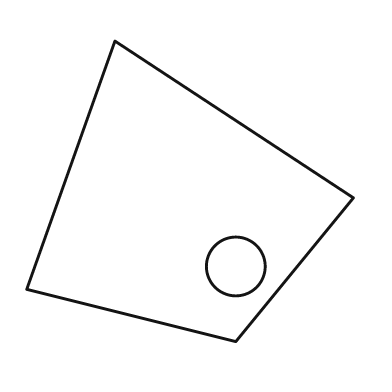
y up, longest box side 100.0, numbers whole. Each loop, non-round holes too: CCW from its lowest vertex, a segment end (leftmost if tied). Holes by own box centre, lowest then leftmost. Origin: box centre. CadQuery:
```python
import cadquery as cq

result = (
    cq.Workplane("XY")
    .moveTo(14.0, -46.0)
    .lineTo(50.0, -2.0)
    .lineTo(-23.0, 46.0)
    .lineTo(-50.0, -30.0)
    .close()
    .moveTo(14.0, -23.0)
    .circle(9.0)
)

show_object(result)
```